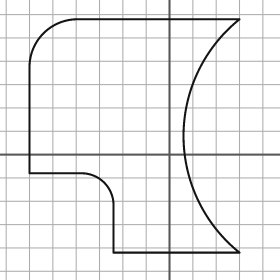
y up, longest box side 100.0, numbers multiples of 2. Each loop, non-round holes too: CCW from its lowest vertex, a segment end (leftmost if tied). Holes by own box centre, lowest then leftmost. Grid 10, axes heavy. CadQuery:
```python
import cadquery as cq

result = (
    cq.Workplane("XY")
    .moveTo(-24.0, -42.0)
    .lineTo(30.0, -42.0)
    .threePointArc((6.0, 8.0), (30.0, 58.0))
    .lineTo(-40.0, 58.0)
    .threePointArc((-54.0, 52.0), (-60.0, 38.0))
    .lineTo(-60.0, -8.0)
    .lineTo(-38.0, -8.0)
    .threePointArc((-28.0, -12.0), (-24.0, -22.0))
    .close()
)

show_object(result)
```